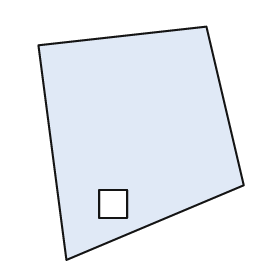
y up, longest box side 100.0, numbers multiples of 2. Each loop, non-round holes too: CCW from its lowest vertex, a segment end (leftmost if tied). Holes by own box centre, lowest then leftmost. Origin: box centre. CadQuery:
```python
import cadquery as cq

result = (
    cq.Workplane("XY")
    .moveTo(-32.0, -50.0)
    .lineTo(44.0, -18.0)
    .lineTo(28.0, 50.0)
    .lineTo(-44.0, 42.0)
    .close()
    .moveTo(-18.0, -32.0)
    .lineTo(-6.0, -32.0)
    .lineTo(-6.0, -20.0)
    .lineTo(-18.0, -20.0)
    .close()
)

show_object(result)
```